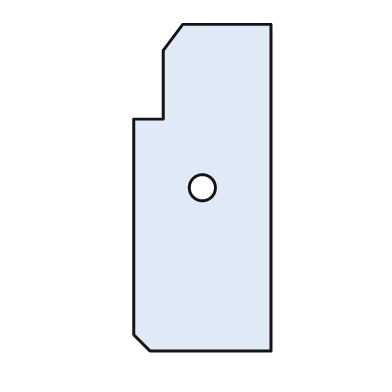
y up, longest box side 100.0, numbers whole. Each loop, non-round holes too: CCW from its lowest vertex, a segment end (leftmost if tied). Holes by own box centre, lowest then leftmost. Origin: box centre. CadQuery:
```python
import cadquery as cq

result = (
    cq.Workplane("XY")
    .moveTo(-16.0, -50.0)
    .lineTo(21.0, -50.0)
    .lineTo(21.0, 50.0)
    .lineTo(-6.0, 50.0)
    .lineTo(-12.0, 42.0)
    .lineTo(-12.0, 21.0)
    .lineTo(-21.0, 21.0)
    .lineTo(-21.0, -45.0)
    .close()
    .moveTo(0.0, 0.0)
    .circle(4.0)
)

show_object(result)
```